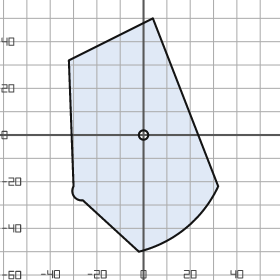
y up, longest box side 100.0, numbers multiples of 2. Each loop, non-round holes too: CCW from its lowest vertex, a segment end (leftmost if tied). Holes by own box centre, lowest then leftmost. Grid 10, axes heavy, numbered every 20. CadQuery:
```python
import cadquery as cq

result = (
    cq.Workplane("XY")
    .moveTo(-2.0, -50.0)
    .threePointArc((18.0, -40.0), (32.0, -22.0))
    .lineTo(4.0, 50.0)
    .lineTo(-32.0, 32.0)
    .lineTo(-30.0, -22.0)
    .threePointArc((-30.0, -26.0), (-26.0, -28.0))
    .close()
    .moveTo(0.0, 0.0)
    .circle(2.0)
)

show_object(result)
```